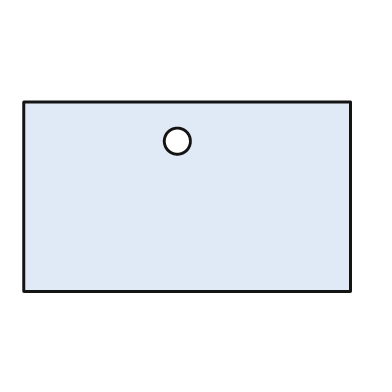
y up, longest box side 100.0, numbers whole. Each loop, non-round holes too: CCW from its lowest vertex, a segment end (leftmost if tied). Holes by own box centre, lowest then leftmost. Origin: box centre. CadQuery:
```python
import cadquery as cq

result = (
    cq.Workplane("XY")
    .moveTo(-50.0, -29.0)
    .lineTo(50.0, -29.0)
    .lineTo(50.0, 29.0)
    .lineTo(-50.0, 29.0)
    .close()
    .moveTo(-3.0, 17.0)
    .circle(4.0)
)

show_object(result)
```